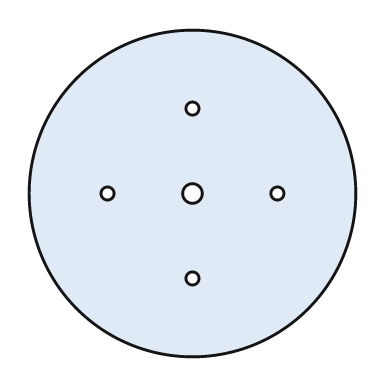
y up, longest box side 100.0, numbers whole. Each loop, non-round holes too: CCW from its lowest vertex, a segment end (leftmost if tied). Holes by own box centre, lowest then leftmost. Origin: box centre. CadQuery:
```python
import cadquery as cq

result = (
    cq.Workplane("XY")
    .moveTo(0.0, 0.0)
    .circle(50.0)
    .moveTo(0.0, -26.0)
    .circle(2.0)
    .moveTo(-26.0, 0.0)
    .circle(2.0)
    .moveTo(0.0, 0.0)
    .circle(3.0)
    .moveTo(26.0, 0.0)
    .circle(2.0)
    .moveTo(0.0, 26.0)
    .circle(2.0)
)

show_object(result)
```